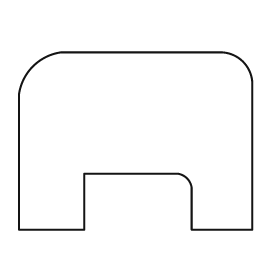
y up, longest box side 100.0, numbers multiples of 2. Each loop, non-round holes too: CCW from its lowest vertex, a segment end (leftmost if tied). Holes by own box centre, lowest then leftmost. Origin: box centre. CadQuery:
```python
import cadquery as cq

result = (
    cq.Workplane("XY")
    .moveTo(-50.0, -38.0)
    .lineTo(-22.0, -38.0)
    .lineTo(-22.0, -14.0)
    .lineTo(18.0, -14.0)
    .threePointArc((22.0, -16.0), (24.0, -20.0))
    .lineTo(24.0, -38.0)
    .lineTo(50.0, -38.0)
    .lineTo(50.0, 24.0)
    .threePointArc((46.0, 34.0), (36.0, 38.0))
    .lineTo(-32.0, 38.0)
    .threePointArc((-44.0, 32.0), (-50.0, 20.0))
    .close()
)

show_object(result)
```